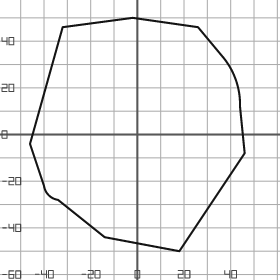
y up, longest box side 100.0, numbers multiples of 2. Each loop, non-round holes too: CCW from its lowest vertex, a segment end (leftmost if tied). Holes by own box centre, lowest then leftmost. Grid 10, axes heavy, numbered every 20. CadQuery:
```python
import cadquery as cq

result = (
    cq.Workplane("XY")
    .moveTo(18.0, -50.0)
    .lineTo(46.0, -8.0)
    .lineTo(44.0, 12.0)
    .threePointArc((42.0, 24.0), (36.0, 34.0))
    .lineTo(26.0, 46.0)
    .lineTo(-2.0, 50.0)
    .lineTo(-32.0, 46.0)
    .lineTo(-46.0, -4.0)
    .lineTo(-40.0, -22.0)
    .threePointArc((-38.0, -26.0), (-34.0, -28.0))
    .lineTo(-14.0, -44.0)
    .close()
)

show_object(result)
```